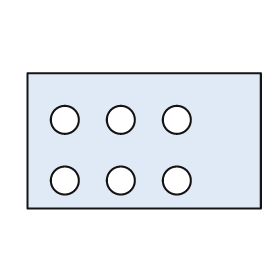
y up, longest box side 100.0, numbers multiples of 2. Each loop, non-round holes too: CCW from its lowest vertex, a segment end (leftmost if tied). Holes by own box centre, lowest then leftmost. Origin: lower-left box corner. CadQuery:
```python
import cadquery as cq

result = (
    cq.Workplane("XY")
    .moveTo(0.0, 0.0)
    .lineTo(100.0, 0.0)
    .lineTo(100.0, 58.0)
    .lineTo(0.0, 58.0)
    .close()
    .moveTo(16.0, 12.0)
    .circle(6.0)
    .moveTo(40.0, 12.0)
    .circle(6.0)
    .moveTo(64.0, 12.0)
    .circle(6.0)
    .moveTo(16.0, 38.0)
    .circle(6.0)
    .moveTo(40.0, 38.0)
    .circle(6.0)
    .moveTo(64.0, 38.0)
    .circle(6.0)
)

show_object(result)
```